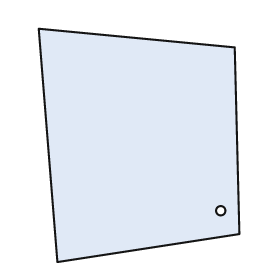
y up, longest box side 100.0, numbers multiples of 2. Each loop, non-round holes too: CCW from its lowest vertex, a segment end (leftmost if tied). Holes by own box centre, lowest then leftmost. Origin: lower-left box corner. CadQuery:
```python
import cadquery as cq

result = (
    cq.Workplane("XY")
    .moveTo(8.0, 0.0)
    .lineTo(86.0, 12.0)
    .lineTo(84.0, 92.0)
    .lineTo(0.0, 100.0)
    .close()
    .moveTo(78.0, 22.0)
    .circle(2.0)
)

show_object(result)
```